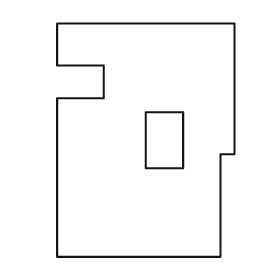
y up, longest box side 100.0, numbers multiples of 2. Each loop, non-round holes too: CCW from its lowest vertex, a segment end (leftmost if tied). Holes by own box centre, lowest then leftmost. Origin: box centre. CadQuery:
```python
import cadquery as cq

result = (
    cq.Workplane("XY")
    .moveTo(-38.0, -50.0)
    .lineTo(32.0, -50.0)
    .lineTo(32.0, -6.0)
    .lineTo(38.0, -6.0)
    .lineTo(38.0, 50.0)
    .lineTo(-38.0, 50.0)
    .lineTo(-38.0, 32.0)
    .lineTo(-18.0, 32.0)
    .lineTo(-18.0, 18.0)
    .lineTo(-38.0, 18.0)
    .close()
    .moveTo(0.0, -12.0)
    .lineTo(16.0, -12.0)
    .lineTo(16.0, 12.0)
    .lineTo(0.0, 12.0)
    .close()
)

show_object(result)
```